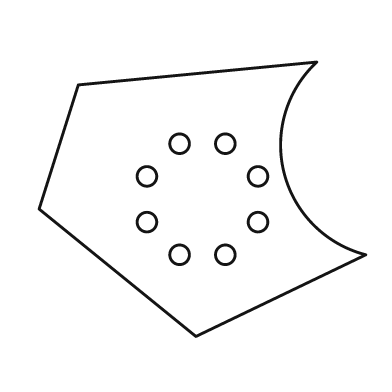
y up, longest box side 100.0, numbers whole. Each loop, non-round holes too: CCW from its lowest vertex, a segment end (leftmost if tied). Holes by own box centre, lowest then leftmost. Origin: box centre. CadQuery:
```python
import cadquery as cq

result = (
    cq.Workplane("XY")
    .moveTo(-2.0, -42.0)
    .lineTo(50.0, -17.0)
    .threePointArc((25.0, 8.0), (35.0, 42.0))
    .lineTo(-38.0, 35.0)
    .lineTo(-50.0, -3.0)
    .close()
    .moveTo(-7.0, -17.0)
    .circle(3.0)
    .moveTo(7.0, -17.0)
    .circle(3.0)
    .moveTo(-17.0, -7.0)
    .circle(3.0)
    .moveTo(17.0, -7.0)
    .circle(3.0)
    .moveTo(-17.0, 7.0)
    .circle(3.0)
    .moveTo(17.0, 7.0)
    .circle(3.0)
    .moveTo(-7.0, 17.0)
    .circle(3.0)
    .moveTo(7.0, 17.0)
    .circle(3.0)
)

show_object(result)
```